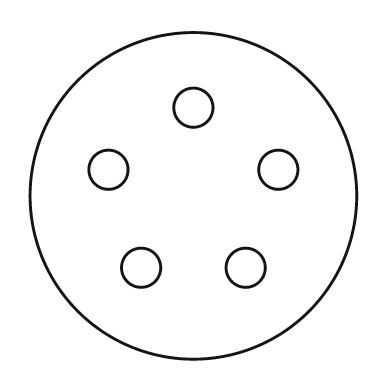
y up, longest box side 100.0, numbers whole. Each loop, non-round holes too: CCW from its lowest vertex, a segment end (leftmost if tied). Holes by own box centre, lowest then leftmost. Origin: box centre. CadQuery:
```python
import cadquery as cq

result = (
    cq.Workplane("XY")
    .moveTo(0.0, 0.0)
    .circle(50.0)
    .moveTo(-16.0, -22.0)
    .circle(6.0)
    .moveTo(16.0, -22.0)
    .circle(6.0)
    .moveTo(-26.0, 8.0)
    .circle(6.0)
    .moveTo(26.0, 8.0)
    .circle(6.0)
    .moveTo(0.0, 27.0)
    .circle(6.0)
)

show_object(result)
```